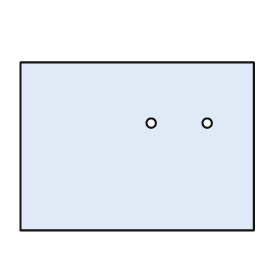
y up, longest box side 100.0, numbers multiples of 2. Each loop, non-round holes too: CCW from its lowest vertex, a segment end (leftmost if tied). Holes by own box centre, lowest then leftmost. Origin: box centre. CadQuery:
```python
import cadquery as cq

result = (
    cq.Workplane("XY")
    .moveTo(-50.0, -36.0)
    .lineTo(50.0, -36.0)
    .lineTo(50.0, 36.0)
    .lineTo(-50.0, 36.0)
    .close()
    .moveTo(6.0, 10.0)
    .circle(2.0)
    .moveTo(30.0, 10.0)
    .circle(2.0)
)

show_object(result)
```